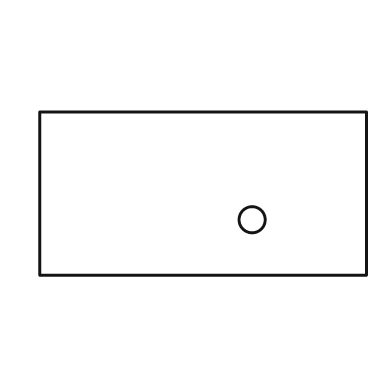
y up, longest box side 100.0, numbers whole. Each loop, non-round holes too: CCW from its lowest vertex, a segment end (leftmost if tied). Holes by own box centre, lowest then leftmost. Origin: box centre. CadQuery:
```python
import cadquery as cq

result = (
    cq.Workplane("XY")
    .moveTo(-50.0, -25.0)
    .lineTo(50.0, -25.0)
    .lineTo(50.0, 25.0)
    .lineTo(-50.0, 25.0)
    .close()
    .moveTo(15.0, -8.0)
    .circle(4.0)
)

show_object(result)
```